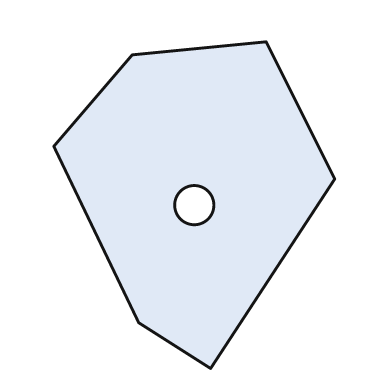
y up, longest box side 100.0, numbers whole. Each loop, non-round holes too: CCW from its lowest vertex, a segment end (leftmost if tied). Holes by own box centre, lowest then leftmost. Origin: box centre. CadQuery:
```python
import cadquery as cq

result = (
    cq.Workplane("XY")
    .moveTo(5.0, -50.0)
    .lineTo(43.0, 8.0)
    .lineTo(22.0, 50.0)
    .lineTo(-19.0, 46.0)
    .lineTo(-43.0, 18.0)
    .lineTo(-17.0, -36.0)
    .close()
    .moveTo(0.0, 0.0)
    .circle(6.0)
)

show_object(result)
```